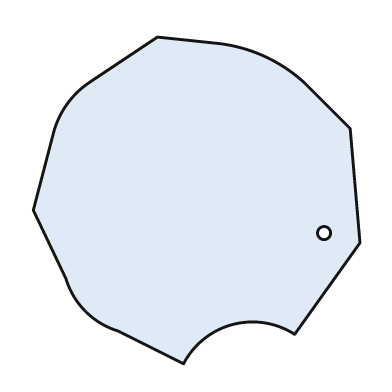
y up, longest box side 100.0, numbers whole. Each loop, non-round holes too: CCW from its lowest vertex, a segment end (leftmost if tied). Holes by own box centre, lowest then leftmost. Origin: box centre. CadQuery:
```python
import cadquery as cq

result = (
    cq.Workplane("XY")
    .moveTo(-4.0, -50.0)
    .threePointArc((11.0, -38.0), (30.0, -41.0))
    .lineTo(50.0, -13.0)
    .lineTo(47.0, 22.0)
    .lineTo(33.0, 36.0)
    .threePointArc((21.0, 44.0), (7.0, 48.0))
    .lineTo(-12.0, 50.0)
    .lineTo(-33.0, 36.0)
    .threePointArc((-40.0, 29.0), (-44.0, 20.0))
    .lineTo(-50.0, -3.0)
    .lineTo(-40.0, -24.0)
    .threePointArc((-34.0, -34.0), (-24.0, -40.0))
    .close()
    .moveTo(39.0, -10.0)
    .circle(2.0)
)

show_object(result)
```